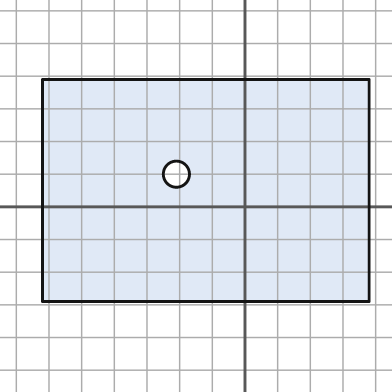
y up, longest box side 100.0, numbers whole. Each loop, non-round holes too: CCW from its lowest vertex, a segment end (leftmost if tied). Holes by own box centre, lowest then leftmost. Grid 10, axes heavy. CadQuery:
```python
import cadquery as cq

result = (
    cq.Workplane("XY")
    .moveTo(-62.0, -29.0)
    .lineTo(38.0, -29.0)
    .lineTo(38.0, 39.0)
    .lineTo(-62.0, 39.0)
    .close()
    .moveTo(-21.0, 10.0)
    .circle(4.0)
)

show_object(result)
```